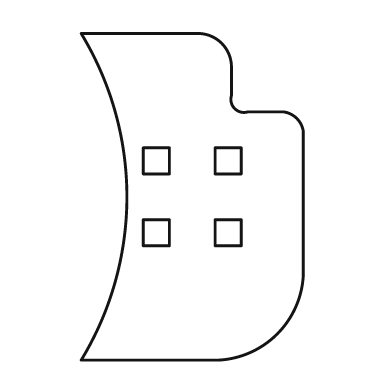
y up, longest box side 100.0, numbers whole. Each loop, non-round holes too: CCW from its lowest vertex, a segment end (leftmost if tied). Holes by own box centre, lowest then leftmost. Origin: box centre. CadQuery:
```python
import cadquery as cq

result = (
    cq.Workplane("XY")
    .moveTo(-34.0, -50.0)
    .lineTo(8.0, -50.0)
    .threePointArc((26.0, -42.0), (34.0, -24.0))
    .lineTo(34.0, 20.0)
    .threePointArc((32.0, 24.0), (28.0, 26.0))
    .lineTo(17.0, 26.0)
    .threePointArc((13.0, 27.0), (12.0, 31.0))
    .lineTo(12.0, 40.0)
    .threePointArc((9.0, 47.0), (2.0, 50.0))
    .lineTo(-34.0, 50.0)
    .threePointArc((-20.0, 0.0), (-34.0, -50.0))
    .close()
    .moveTo(-15.0, -15.0)
    .lineTo(-7.0, -15.0)
    .lineTo(-7.0, -7.0)
    .lineTo(-15.0, -7.0)
    .close()
    .moveTo(7.0, -15.0)
    .lineTo(15.0, -15.0)
    .lineTo(15.0, -7.0)
    .lineTo(7.0, -7.0)
    .close()
    .moveTo(-15.0, 7.0)
    .lineTo(-7.0, 7.0)
    .lineTo(-7.0, 15.0)
    .lineTo(-15.0, 15.0)
    .close()
    .moveTo(7.0, 7.0)
    .lineTo(15.0, 7.0)
    .lineTo(15.0, 15.0)
    .lineTo(7.0, 15.0)
    .close()
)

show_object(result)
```